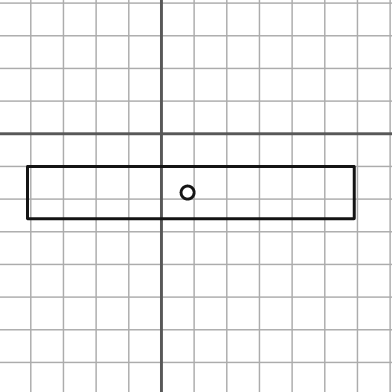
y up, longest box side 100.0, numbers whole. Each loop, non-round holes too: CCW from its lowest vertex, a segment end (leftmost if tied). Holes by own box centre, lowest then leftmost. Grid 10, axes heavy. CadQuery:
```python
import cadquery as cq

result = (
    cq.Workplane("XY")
    .moveTo(-41.0, -26.0)
    .lineTo(59.0, -26.0)
    .lineTo(59.0, -10.0)
    .lineTo(-41.0, -10.0)
    .close()
    .moveTo(8.0, -18.0)
    .circle(2.0)
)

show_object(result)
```